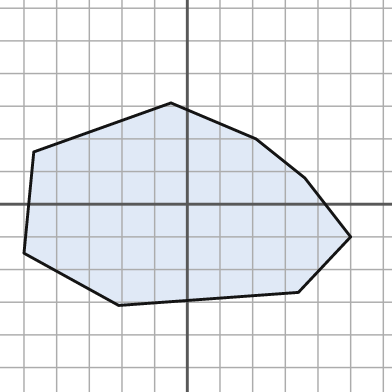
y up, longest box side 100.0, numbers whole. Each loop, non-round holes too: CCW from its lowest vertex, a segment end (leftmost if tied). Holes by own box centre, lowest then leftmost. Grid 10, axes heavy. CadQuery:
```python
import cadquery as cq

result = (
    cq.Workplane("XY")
    .moveTo(-21.0, -31.0)
    .lineTo(34.0, -27.0)
    .lineTo(50.0, -10.0)
    .lineTo(36.0, 8.0)
    .lineTo(21.0, 20.0)
    .lineTo(-5.0, 31.0)
    .lineTo(-47.0, 16.0)
    .lineTo(-50.0, -15.0)
    .close()
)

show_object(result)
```